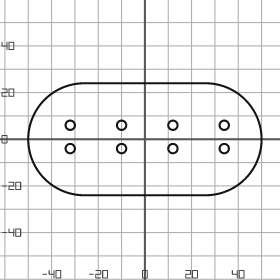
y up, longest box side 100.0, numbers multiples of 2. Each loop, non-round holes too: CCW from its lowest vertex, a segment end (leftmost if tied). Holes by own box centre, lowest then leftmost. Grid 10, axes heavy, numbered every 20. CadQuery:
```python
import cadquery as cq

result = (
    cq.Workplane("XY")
    .moveTo(-26.0, -24.0)
    .lineTo(26.0, -24.0)
    .threePointArc((50.0, 0.0), (26.0, 24.0))
    .lineTo(-26.0, 24.0)
    .threePointArc((-50.0, 0.0), (-26.0, -24.0))
    .close()
    .moveTo(-32.0, -4.0)
    .circle(2.0)
    .moveTo(-10.0, -4.0)
    .circle(2.0)
    .moveTo(12.0, -4.0)
    .circle(2.0)
    .moveTo(34.0, -4.0)
    .circle(2.0)
    .moveTo(-32.0, 6.0)
    .circle(2.0)
    .moveTo(-10.0, 6.0)
    .circle(2.0)
    .moveTo(12.0, 6.0)
    .circle(2.0)
    .moveTo(34.0, 6.0)
    .circle(2.0)
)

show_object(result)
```